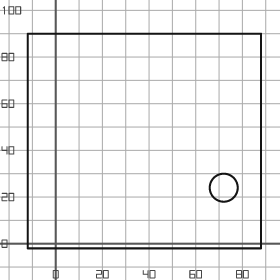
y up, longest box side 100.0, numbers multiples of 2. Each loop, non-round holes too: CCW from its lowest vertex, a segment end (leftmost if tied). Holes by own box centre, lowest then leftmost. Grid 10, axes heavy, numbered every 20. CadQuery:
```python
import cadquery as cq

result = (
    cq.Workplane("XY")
    .moveTo(-12.0, -2.0)
    .lineTo(88.0, -2.0)
    .lineTo(88.0, 90.0)
    .lineTo(-12.0, 90.0)
    .close()
    .moveTo(72.0, 24.0)
    .circle(6.0)
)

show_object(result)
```